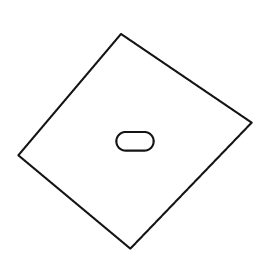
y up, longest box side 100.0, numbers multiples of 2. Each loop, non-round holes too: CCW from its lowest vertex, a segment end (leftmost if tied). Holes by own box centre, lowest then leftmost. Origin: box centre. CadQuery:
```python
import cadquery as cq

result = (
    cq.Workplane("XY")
    .moveTo(-2.0, -46.0)
    .lineTo(50.0, 8.0)
    .lineTo(-6.0, 46.0)
    .lineTo(-50.0, -6.0)
    .close()
    .moveTo(-4.0, -4.0)
    .lineTo(4.0, -4.0)
    .threePointArc((8.0, 0.0), (4.0, 4.0))
    .lineTo(-4.0, 4.0)
    .threePointArc((-8.0, 0.0), (-4.0, -4.0))
    .close()
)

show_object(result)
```